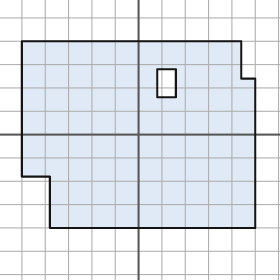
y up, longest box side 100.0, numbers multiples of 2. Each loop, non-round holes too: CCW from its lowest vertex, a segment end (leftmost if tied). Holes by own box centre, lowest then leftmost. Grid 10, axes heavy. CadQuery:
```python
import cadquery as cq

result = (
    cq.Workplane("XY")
    .moveTo(-38.0, -40.0)
    .lineTo(50.0, -40.0)
    .lineTo(50.0, 24.0)
    .lineTo(44.0, 24.0)
    .lineTo(44.0, 40.0)
    .lineTo(-50.0, 40.0)
    .lineTo(-50.0, -18.0)
    .lineTo(-38.0, -18.0)
    .close()
    .moveTo(8.0, 16.0)
    .lineTo(16.0, 16.0)
    .lineTo(16.0, 28.0)
    .lineTo(8.0, 28.0)
    .close()
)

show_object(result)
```